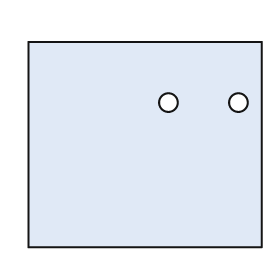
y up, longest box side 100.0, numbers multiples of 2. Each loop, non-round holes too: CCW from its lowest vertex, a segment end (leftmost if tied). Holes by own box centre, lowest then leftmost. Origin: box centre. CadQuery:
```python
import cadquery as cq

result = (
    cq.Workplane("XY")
    .moveTo(-50.0, -44.0)
    .lineTo(50.0, -44.0)
    .lineTo(50.0, 44.0)
    .lineTo(-50.0, 44.0)
    .close()
    .moveTo(10.0, 18.0)
    .circle(4.0)
    .moveTo(40.0, 18.0)
    .circle(4.0)
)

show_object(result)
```